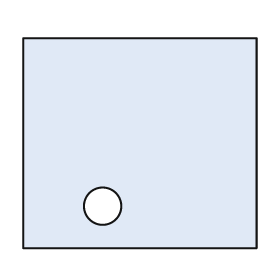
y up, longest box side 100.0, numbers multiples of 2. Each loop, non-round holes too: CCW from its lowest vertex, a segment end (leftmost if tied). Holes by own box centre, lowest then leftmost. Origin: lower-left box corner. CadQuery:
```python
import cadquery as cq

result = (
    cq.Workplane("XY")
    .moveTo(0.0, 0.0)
    .lineTo(100.0, 0.0)
    .lineTo(100.0, 90.0)
    .lineTo(0.0, 90.0)
    .close()
    .moveTo(34.0, 18.0)
    .circle(8.0)
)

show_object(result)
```